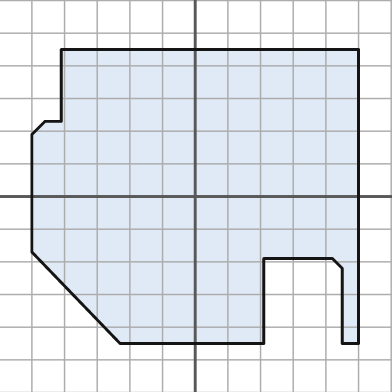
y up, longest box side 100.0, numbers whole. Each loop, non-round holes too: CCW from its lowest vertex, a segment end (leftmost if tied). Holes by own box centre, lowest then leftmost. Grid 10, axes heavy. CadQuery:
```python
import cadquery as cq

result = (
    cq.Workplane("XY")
    .moveTo(-23.0, -45.0)
    .lineTo(21.0, -45.0)
    .lineTo(21.0, -19.0)
    .lineTo(42.0, -19.0)
    .lineTo(45.0, -22.0)
    .lineTo(45.0, -45.0)
    .lineTo(50.0, -45.0)
    .lineTo(50.0, 45.0)
    .lineTo(-41.0, 45.0)
    .lineTo(-41.0, 23.0)
    .lineTo(-46.0, 23.0)
    .lineTo(-50.0, 19.0)
    .lineTo(-50.0, -17.0)
    .close()
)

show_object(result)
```